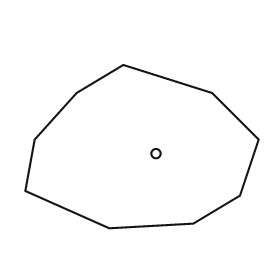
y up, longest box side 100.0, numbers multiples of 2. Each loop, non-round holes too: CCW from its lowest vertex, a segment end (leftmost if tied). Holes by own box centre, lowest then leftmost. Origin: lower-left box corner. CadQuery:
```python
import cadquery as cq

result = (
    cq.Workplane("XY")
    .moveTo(36.0, 0.0)
    .lineTo(72.0, 2.0)
    .lineTo(92.0, 14.0)
    .lineTo(100.0, 38.0)
    .lineTo(80.0, 58.0)
    .lineTo(42.0, 70.0)
    .lineTo(22.0, 58.0)
    .lineTo(4.0, 38.0)
    .lineTo(0.0, 16.0)
    .close()
    .moveTo(56.0, 32.0)
    .circle(2.0)
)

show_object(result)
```